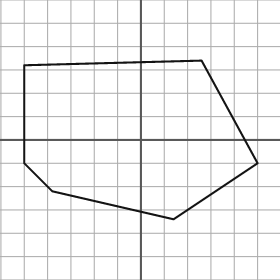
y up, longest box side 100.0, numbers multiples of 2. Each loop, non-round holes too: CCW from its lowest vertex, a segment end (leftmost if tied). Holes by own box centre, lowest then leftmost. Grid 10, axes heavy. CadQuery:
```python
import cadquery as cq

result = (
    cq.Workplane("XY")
    .moveTo(14.0, -34.0)
    .lineTo(50.0, -10.0)
    .lineTo(26.0, 34.0)
    .lineTo(-50.0, 32.0)
    .lineTo(-50.0, -10.0)
    .lineTo(-38.0, -22.0)
    .close()
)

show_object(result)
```